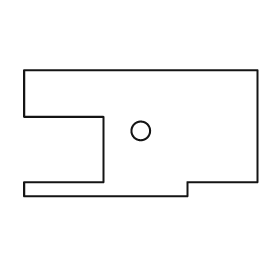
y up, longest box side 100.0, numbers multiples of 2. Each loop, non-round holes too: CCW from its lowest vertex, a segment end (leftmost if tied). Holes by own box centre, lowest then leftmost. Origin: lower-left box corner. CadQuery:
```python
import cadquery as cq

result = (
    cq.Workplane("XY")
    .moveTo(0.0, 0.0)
    .lineTo(70.0, 0.0)
    .lineTo(70.0, 6.0)
    .lineTo(100.0, 6.0)
    .lineTo(100.0, 54.0)
    .lineTo(0.0, 54.0)
    .lineTo(0.0, 34.0)
    .lineTo(34.0, 34.0)
    .lineTo(34.0, 6.0)
    .lineTo(0.0, 6.0)
    .close()
    .moveTo(50.0, 28.0)
    .circle(4.0)
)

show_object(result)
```